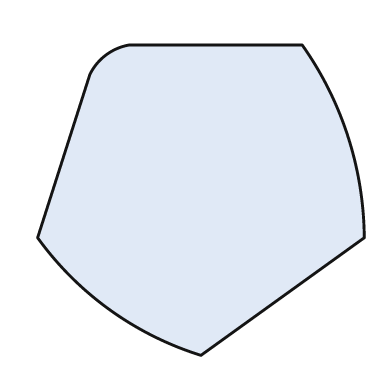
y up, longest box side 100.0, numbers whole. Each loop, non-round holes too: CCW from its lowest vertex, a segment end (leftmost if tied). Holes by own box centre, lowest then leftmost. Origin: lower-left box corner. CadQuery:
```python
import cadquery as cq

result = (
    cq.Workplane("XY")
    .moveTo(50.0, 0.0)
    .lineTo(100.0, 36.0)
    .threePointArc((95.0, 67.0), (81.0, 95.0))
    .lineTo(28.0, 95.0)
    .threePointArc((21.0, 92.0), (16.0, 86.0))
    .lineTo(0.0, 36.0)
    .threePointArc((22.0, 14.0), (50.0, 0.0))
    .close()
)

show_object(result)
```